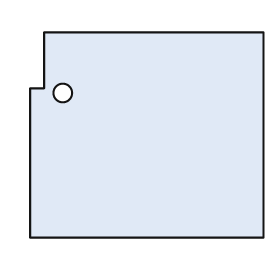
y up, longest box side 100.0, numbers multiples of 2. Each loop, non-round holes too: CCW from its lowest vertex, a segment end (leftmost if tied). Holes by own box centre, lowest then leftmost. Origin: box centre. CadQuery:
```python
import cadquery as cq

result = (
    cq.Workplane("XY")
    .moveTo(-50.0, -44.0)
    .lineTo(50.0, -44.0)
    .lineTo(50.0, 44.0)
    .lineTo(-44.0, 44.0)
    .lineTo(-44.0, 20.0)
    .lineTo(-50.0, 20.0)
    .close()
    .moveTo(-36.0, 18.0)
    .circle(4.0)
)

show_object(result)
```